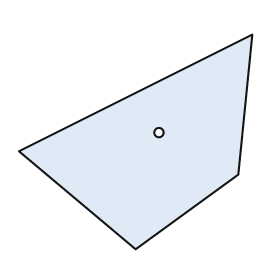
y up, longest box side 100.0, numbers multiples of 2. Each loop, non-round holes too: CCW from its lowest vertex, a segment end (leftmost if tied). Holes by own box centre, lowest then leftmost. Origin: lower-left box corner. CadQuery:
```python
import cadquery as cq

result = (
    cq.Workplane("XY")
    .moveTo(50.0, 0.0)
    .lineTo(94.0, 32.0)
    .lineTo(100.0, 92.0)
    .lineTo(0.0, 42.0)
    .close()
    .moveTo(60.0, 50.0)
    .circle(2.0)
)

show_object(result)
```